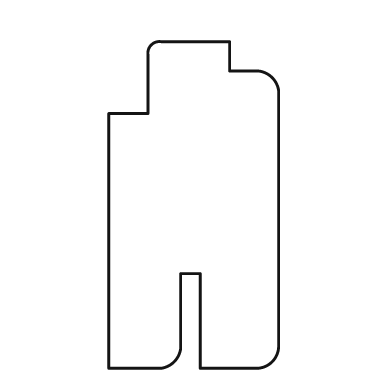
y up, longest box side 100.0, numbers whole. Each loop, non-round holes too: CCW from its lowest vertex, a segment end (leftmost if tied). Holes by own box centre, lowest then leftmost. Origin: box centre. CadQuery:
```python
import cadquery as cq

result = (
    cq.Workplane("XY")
    .moveTo(-26.0, -50.0)
    .lineTo(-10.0, -50.0)
    .threePointArc((-6.0, -48.0), (-4.0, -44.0))
    .lineTo(-4.0, -21.0)
    .lineTo(2.0, -21.0)
    .lineTo(2.0, -50.0)
    .lineTo(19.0, -50.0)
    .threePointArc((24.0, -48.0), (26.0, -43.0))
    .lineTo(26.0, 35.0)
    .threePointArc((24.0, 39.0), (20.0, 41.0))
    .lineTo(11.0, 41.0)
    .lineTo(11.0, 50.0)
    .lineTo(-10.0, 50.0)
    .threePointArc((-13.0, 49.0), (-14.0, 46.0))
    .lineTo(-14.0, 28.0)
    .lineTo(-26.0, 28.0)
    .close()
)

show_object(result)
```